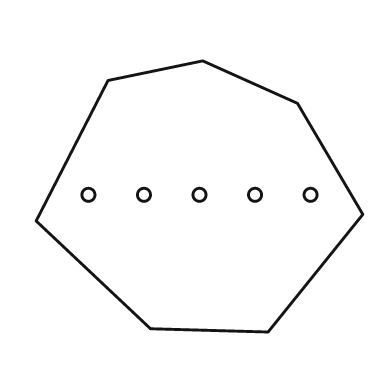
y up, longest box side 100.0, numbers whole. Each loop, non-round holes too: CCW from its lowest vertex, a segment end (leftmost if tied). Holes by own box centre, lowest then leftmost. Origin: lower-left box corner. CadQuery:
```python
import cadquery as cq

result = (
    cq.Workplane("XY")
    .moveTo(71.0, 0.0)
    .lineTo(100.0, 36.0)
    .lineTo(80.0, 70.0)
    .lineTo(51.0, 83.0)
    .lineTo(22.0, 77.0)
    .lineTo(0.0, 34.0)
    .lineTo(35.0, 1.0)
    .close()
    .moveTo(16.0, 42.0)
    .circle(2.0)
    .moveTo(33.0, 42.0)
    .circle(2.0)
    .moveTo(50.0, 42.0)
    .circle(2.0)
    .moveTo(67.0, 42.0)
    .circle(2.0)
    .moveTo(84.0, 42.0)
    .circle(2.0)
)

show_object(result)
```